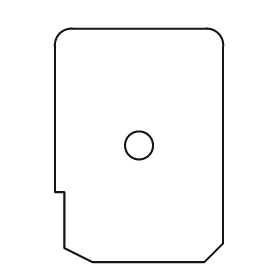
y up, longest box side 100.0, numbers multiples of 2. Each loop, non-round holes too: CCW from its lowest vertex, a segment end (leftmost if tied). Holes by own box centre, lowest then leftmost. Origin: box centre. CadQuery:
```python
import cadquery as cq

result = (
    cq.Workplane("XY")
    .moveTo(-20.0, -50.0)
    .lineTo(28.0, -50.0)
    .lineTo(36.0, -42.0)
    .lineTo(36.0, 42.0)
    .threePointArc((34.0, 48.0), (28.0, 50.0))
    .lineTo(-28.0, 50.0)
    .threePointArc((-34.0, 48.0), (-36.0, 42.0))
    .lineTo(-36.0, -20.0)
    .lineTo(-32.0, -20.0)
    .lineTo(-32.0, -44.0)
    .close()
    .moveTo(0.0, 0.0)
    .circle(6.0)
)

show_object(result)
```